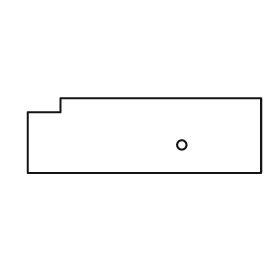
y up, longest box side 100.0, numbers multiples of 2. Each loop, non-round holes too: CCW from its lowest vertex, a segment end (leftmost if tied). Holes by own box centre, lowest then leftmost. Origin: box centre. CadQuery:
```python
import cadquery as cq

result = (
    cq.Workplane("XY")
    .moveTo(-50.0, -16.0)
    .lineTo(50.0, -16.0)
    .lineTo(50.0, 16.0)
    .lineTo(-36.0, 16.0)
    .lineTo(-36.0, 10.0)
    .lineTo(-50.0, 10.0)
    .close()
    .moveTo(16.0, -4.0)
    .circle(2.0)
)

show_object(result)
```